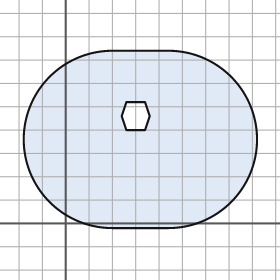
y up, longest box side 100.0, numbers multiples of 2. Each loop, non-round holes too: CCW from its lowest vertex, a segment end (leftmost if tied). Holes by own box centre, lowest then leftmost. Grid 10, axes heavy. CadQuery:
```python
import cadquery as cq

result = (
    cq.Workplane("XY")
    .moveTo(20.0, -2.0)
    .lineTo(44.0, -2.0)
    .threePointArc((82.0, 36.0), (44.0, 74.0))
    .lineTo(20.0, 74.0)
    .threePointArc((-18.0, 36.0), (20.0, -2.0))
    .close()
    .moveTo(26.0, 40.0)
    .lineTo(34.0, 40.0)
    .lineTo(36.0, 46.0)
    .lineTo(34.0, 52.0)
    .lineTo(26.0, 52.0)
    .lineTo(24.0, 46.0)
    .close()
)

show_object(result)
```